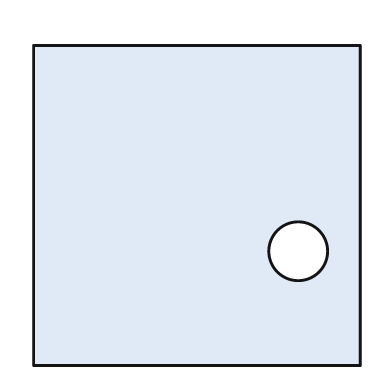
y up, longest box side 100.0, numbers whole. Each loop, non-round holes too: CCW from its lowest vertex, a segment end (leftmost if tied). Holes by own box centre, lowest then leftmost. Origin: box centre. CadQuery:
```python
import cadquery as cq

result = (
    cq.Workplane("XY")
    .moveTo(-50.0, -49.0)
    .lineTo(50.0, -49.0)
    .lineTo(50.0, 49.0)
    .lineTo(-50.0, 49.0)
    .close()
    .moveTo(31.0, -14.0)
    .circle(9.0)
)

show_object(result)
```